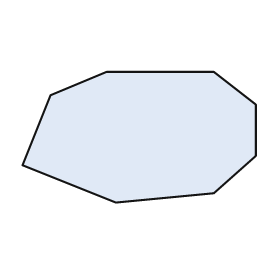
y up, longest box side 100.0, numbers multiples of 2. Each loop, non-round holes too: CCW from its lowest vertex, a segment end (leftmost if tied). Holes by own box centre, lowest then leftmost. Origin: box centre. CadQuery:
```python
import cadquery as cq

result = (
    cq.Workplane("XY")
    .moveTo(-10.0, -28.0)
    .lineTo(32.0, -24.0)
    .lineTo(50.0, -8.0)
    .lineTo(50.0, 14.0)
    .lineTo(32.0, 28.0)
    .lineTo(-14.0, 28.0)
    .lineTo(-38.0, 18.0)
    .lineTo(-50.0, -12.0)
    .close()
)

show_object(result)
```